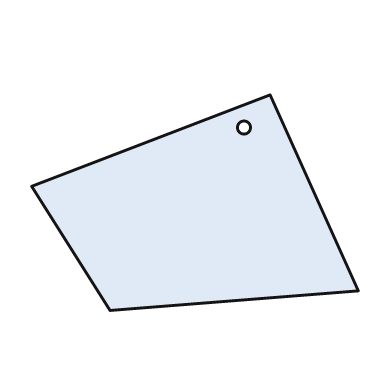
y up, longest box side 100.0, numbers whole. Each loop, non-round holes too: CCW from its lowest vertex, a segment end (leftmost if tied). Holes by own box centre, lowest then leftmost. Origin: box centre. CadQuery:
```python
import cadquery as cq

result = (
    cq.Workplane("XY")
    .moveTo(-26.0, -33.0)
    .lineTo(50.0, -27.0)
    .lineTo(23.0, 33.0)
    .lineTo(-50.0, 5.0)
    .close()
    .moveTo(15.0, 23.0)
    .circle(2.0)
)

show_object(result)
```